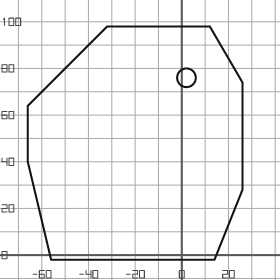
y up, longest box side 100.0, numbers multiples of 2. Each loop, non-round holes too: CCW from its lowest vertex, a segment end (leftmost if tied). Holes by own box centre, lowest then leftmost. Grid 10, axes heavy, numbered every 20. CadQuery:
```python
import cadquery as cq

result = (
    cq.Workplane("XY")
    .moveTo(-56.0, -2.0)
    .lineTo(14.0, -2.0)
    .lineTo(26.0, 28.0)
    .lineTo(26.0, 74.0)
    .lineTo(12.0, 98.0)
    .lineTo(-32.0, 98.0)
    .lineTo(-66.0, 64.0)
    .lineTo(-66.0, 40.0)
    .close()
    .moveTo(2.0, 76.0)
    .circle(4.0)
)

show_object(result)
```